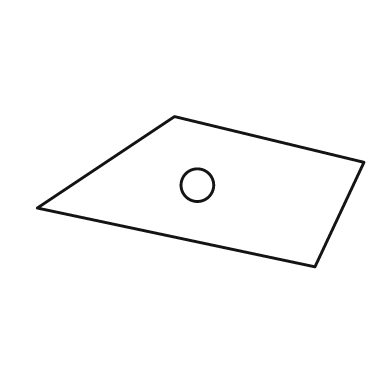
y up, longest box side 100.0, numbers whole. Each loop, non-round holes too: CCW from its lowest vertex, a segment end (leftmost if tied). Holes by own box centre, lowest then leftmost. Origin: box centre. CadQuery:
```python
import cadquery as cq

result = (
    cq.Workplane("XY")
    .moveTo(35.0, -23.0)
    .lineTo(50.0, 9.0)
    .lineTo(-8.0, 23.0)
    .lineTo(-50.0, -5.0)
    .close()
    .moveTo(-1.0, 2.0)
    .circle(5.0)
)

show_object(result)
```